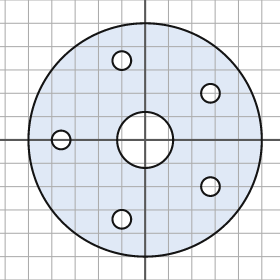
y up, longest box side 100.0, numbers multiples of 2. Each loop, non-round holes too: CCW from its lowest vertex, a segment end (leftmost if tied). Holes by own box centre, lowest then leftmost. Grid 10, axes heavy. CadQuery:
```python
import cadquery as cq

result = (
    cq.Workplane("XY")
    .moveTo(0.0, 0.0)
    .circle(50.0)
    .moveTo(-10.0, -34.0)
    .circle(4.0)
    .moveTo(28.0, -20.0)
    .circle(4.0)
    .moveTo(-36.0, 0.0)
    .circle(4.0)
    .moveTo(0.0, 0.0)
    .circle(12.0)
    .moveTo(28.0, 20.0)
    .circle(4.0)
    .moveTo(-10.0, 34.0)
    .circle(4.0)
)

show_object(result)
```